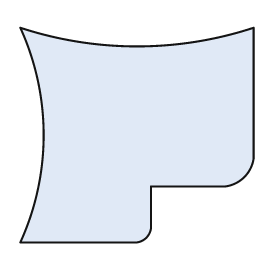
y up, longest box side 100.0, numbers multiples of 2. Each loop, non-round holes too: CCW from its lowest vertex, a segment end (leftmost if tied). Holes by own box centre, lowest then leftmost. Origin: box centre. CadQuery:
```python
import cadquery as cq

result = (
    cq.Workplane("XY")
    .moveTo(-50.0, -46.0)
    .lineTo(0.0, -46.0)
    .threePointArc((4.0, -44.0), (6.0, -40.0))
    .lineTo(6.0, -22.0)
    .lineTo(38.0, -22.0)
    .threePointArc((46.0, -18.0), (50.0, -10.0))
    .lineTo(50.0, 46.0)
    .threePointArc((0.0, 38.0), (-50.0, 46.0))
    .threePointArc((-40.0, 0.0), (-50.0, -46.0))
    .close()
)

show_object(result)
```